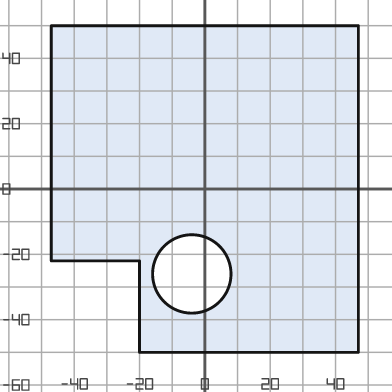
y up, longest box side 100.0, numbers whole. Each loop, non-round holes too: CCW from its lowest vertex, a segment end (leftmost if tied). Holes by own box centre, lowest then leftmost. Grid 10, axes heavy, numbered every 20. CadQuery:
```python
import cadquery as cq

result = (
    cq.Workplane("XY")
    .moveTo(-20.0, -50.0)
    .lineTo(47.0, -50.0)
    .lineTo(47.0, 50.0)
    .lineTo(-47.0, 50.0)
    .lineTo(-47.0, -22.0)
    .lineTo(-20.0, -22.0)
    .close()
    .moveTo(-4.0, -26.0)
    .circle(12.0)
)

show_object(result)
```